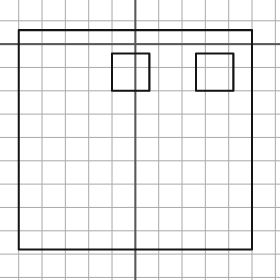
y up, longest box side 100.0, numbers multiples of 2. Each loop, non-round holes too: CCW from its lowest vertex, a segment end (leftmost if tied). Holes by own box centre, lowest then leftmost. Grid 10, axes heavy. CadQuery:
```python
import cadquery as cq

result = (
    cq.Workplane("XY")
    .moveTo(-50.0, -88.0)
    .lineTo(50.0, -88.0)
    .lineTo(50.0, 6.0)
    .lineTo(-50.0, 6.0)
    .close()
    .moveTo(-10.0, -20.0)
    .lineTo(6.0, -20.0)
    .lineTo(6.0, -4.0)
    .lineTo(-10.0, -4.0)
    .close()
    .moveTo(26.0, -20.0)
    .lineTo(42.0, -20.0)
    .lineTo(42.0, -4.0)
    .lineTo(26.0, -4.0)
    .close()
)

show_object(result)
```